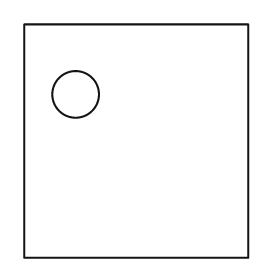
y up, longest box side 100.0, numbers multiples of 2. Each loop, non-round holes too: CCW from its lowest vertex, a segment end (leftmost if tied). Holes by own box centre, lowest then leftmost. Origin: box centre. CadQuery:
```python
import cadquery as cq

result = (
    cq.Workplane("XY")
    .moveTo(-48.0, -50.0)
    .lineTo(48.0, -50.0)
    .lineTo(48.0, 50.0)
    .lineTo(-48.0, 50.0)
    .close()
    .moveTo(-26.0, 20.0)
    .circle(10.0)
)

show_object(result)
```